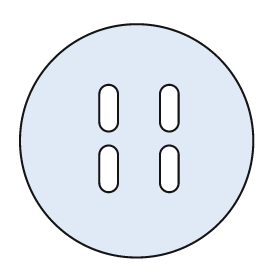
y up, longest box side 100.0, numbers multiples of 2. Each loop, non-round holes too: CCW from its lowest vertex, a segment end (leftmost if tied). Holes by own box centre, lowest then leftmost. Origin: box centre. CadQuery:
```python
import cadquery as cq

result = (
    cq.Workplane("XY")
    .moveTo(0.0, 0.0)
    .circle(50.0)
    .moveTo(-16.0, -18.0)
    .threePointArc((-12.0, -22.0), (-8.0, -18.0))
    .lineTo(-8.0, -6.0)
    .threePointArc((-12.0, -2.0), (-16.0, -6.0))
    .close()
    .moveTo(10.0, -18.0)
    .threePointArc((14.0, -22.0), (18.0, -18.0))
    .lineTo(18.0, -6.0)
    .threePointArc((14.0, -2.0), (10.0, -6.0))
    .close()
    .moveTo(-16.0, 8.0)
    .threePointArc((-12.0, 4.0), (-8.0, 8.0))
    .lineTo(-8.0, 20.0)
    .threePointArc((-12.0, 24.0), (-16.0, 20.0))
    .close()
    .moveTo(10.0, 8.0)
    .threePointArc((14.0, 4.0), (18.0, 8.0))
    .lineTo(18.0, 20.0)
    .threePointArc((14.0, 24.0), (10.0, 20.0))
    .close()
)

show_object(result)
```